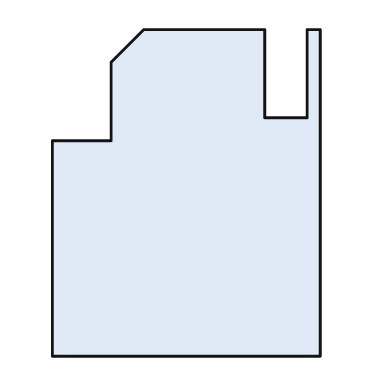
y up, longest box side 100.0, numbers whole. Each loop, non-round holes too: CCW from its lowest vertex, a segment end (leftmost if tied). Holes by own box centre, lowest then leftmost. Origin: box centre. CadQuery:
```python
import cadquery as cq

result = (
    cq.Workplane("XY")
    .moveTo(-41.0, -50.0)
    .lineTo(41.0, -50.0)
    .lineTo(41.0, 50.0)
    .lineTo(37.0, 50.0)
    .lineTo(37.0, 23.0)
    .lineTo(24.0, 23.0)
    .lineTo(24.0, 50.0)
    .lineTo(-13.0, 50.0)
    .lineTo(-23.0, 40.0)
    .lineTo(-23.0, 16.0)
    .lineTo(-41.0, 16.0)
    .close()
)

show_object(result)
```